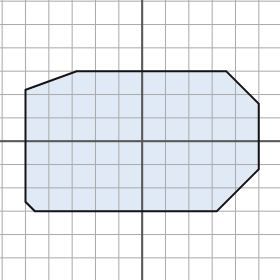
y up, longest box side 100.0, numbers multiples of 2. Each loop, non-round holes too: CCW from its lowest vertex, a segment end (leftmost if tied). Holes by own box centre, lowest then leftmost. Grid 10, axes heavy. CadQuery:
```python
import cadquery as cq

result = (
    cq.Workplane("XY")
    .moveTo(-46.0, -30.0)
    .lineTo(32.0, -30.0)
    .lineTo(50.0, -12.0)
    .lineTo(50.0, 16.0)
    .lineTo(36.0, 30.0)
    .lineTo(-28.0, 30.0)
    .lineTo(-50.0, 22.0)
    .lineTo(-50.0, -26.0)
    .close()
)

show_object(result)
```